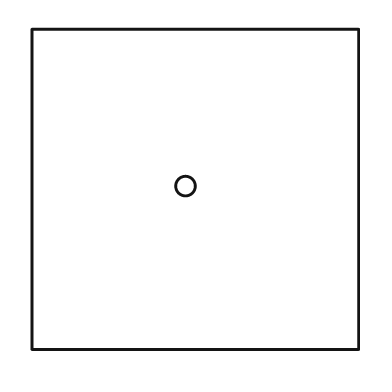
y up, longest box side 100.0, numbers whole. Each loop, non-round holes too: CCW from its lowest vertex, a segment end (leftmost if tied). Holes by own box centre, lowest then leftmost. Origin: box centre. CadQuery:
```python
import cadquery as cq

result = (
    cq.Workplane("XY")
    .moveTo(-50.0, -49.0)
    .lineTo(50.0, -49.0)
    .lineTo(50.0, 49.0)
    .lineTo(-50.0, 49.0)
    .close()
    .moveTo(-3.0, 1.0)
    .circle(3.0)
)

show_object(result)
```